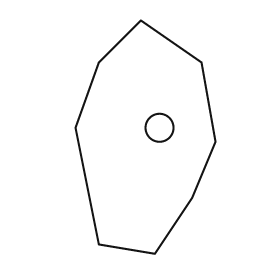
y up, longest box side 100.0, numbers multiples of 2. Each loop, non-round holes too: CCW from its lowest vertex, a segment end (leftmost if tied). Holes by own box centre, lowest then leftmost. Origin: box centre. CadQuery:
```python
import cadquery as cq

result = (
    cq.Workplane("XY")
    .moveTo(4.0, -50.0)
    .lineTo(20.0, -26.0)
    .lineTo(30.0, -2.0)
    .lineTo(24.0, 32.0)
    .lineTo(-2.0, 50.0)
    .lineTo(-20.0, 32.0)
    .lineTo(-30.0, 4.0)
    .lineTo(-20.0, -46.0)
    .close()
    .moveTo(6.0, 4.0)
    .circle(6.0)
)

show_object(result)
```